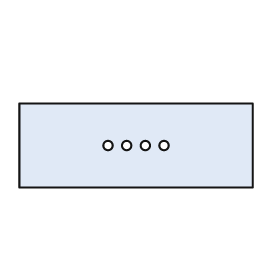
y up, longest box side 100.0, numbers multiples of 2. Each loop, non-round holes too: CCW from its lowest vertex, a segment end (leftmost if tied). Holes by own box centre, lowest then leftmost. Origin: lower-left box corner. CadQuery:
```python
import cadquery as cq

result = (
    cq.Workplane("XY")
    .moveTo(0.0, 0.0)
    .lineTo(100.0, 0.0)
    .lineTo(100.0, 36.0)
    .lineTo(0.0, 36.0)
    .close()
    .moveTo(38.0, 18.0)
    .circle(2.0)
    .moveTo(46.0, 18.0)
    .circle(2.0)
    .moveTo(54.0, 18.0)
    .circle(2.0)
    .moveTo(62.0, 18.0)
    .circle(2.0)
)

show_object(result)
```